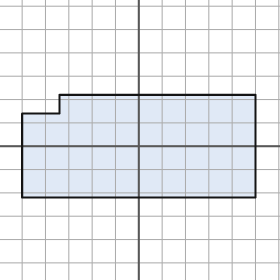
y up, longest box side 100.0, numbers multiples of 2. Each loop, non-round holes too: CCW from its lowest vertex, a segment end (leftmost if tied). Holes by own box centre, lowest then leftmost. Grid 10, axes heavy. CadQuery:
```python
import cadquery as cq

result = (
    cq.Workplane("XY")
    .moveTo(-50.0, -22.0)
    .lineTo(50.0, -22.0)
    .lineTo(50.0, 22.0)
    .lineTo(-34.0, 22.0)
    .lineTo(-34.0, 14.0)
    .lineTo(-50.0, 14.0)
    .close()
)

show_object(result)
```